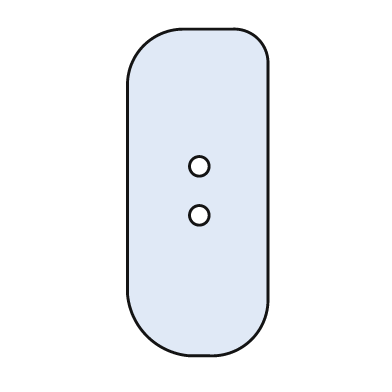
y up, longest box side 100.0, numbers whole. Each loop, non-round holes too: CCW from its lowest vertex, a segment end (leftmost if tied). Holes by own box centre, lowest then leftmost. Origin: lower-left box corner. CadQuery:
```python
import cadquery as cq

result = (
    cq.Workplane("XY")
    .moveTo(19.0, 0.0)
    .lineTo(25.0, 0.0)
    .threePointArc((38.0, 5.0), (43.0, 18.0))
    .lineTo(43.0, 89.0)
    .threePointArc((40.0, 97.0), (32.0, 100.0))
    .lineTo(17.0, 100.0)
    .threePointArc((5.0, 95.0), (0.0, 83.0))
    .lineTo(0.0, 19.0)
    .threePointArc((6.0, 6.0), (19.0, 0.0))
    .close()
    .moveTo(22.0, 43.0)
    .circle(3.0)
    .moveTo(22.0, 58.0)
    .circle(3.0)
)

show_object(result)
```